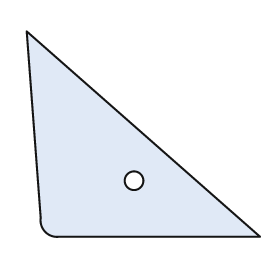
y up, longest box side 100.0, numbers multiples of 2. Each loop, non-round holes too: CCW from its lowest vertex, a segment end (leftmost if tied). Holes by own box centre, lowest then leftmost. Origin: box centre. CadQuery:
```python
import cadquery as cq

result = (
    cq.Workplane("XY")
    .moveTo(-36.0, -44.0)
    .lineTo(50.0, -44.0)
    .lineTo(-50.0, 44.0)
    .lineTo(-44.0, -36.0)
    .threePointArc((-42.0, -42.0), (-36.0, -44.0))
    .close()
    .moveTo(-4.0, -20.0)
    .circle(4.0)
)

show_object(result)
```